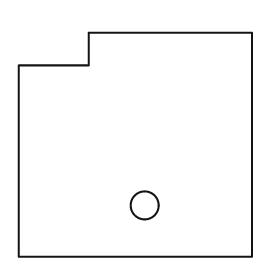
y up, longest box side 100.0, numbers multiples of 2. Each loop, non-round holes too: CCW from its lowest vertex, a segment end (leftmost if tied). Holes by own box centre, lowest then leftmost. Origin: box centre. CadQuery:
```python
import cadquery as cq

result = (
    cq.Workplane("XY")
    .moveTo(-50.0, -48.0)
    .lineTo(50.0, -48.0)
    .lineTo(50.0, 48.0)
    .lineTo(-20.0, 48.0)
    .lineTo(-20.0, 34.0)
    .lineTo(-50.0, 34.0)
    .close()
    .moveTo(4.0, -26.0)
    .circle(6.0)
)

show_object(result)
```